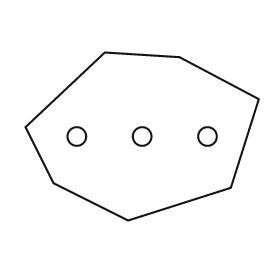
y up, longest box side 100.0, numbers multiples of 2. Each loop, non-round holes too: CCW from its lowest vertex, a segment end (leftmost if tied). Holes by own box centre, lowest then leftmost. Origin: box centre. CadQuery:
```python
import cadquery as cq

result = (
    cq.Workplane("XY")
    .moveTo(-6.0, -36.0)
    .lineTo(38.0, -22.0)
    .lineTo(50.0, 16.0)
    .lineTo(16.0, 34.0)
    .lineTo(-16.0, 36.0)
    .lineTo(-50.0, 4.0)
    .lineTo(-38.0, -20.0)
    .close()
    .moveTo(-28.0, 0.0)
    .circle(4.0)
    .moveTo(0.0, 0.0)
    .circle(4.0)
    .moveTo(28.0, 0.0)
    .circle(4.0)
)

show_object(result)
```